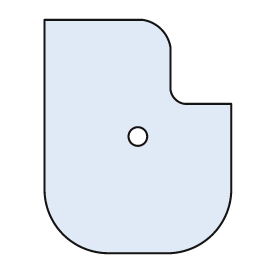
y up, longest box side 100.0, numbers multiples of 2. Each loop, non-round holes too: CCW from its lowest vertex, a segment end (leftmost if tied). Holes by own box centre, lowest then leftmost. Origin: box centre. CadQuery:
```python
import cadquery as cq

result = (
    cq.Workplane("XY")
    .moveTo(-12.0, -50.0)
    .lineTo(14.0, -50.0)
    .threePointArc((32.0, -42.0), (40.0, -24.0))
    .lineTo(40.0, 14.0)
    .lineTo(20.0, 14.0)
    .threePointArc((16.0, 16.0), (14.0, 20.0))
    .lineTo(14.0, 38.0)
    .threePointArc((10.0, 46.0), (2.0, 50.0))
    .lineTo(-40.0, 50.0)
    .lineTo(-40.0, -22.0)
    .threePointArc((-32.0, -42.0), (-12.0, -50.0))
    .close()
    .moveTo(0.0, 0.0)
    .circle(4.0)
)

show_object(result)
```